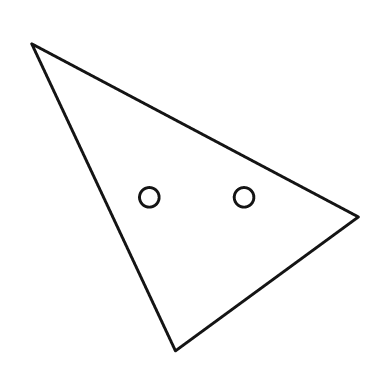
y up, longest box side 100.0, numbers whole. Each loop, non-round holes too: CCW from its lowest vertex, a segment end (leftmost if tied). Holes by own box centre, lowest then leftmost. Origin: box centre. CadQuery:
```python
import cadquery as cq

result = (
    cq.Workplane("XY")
    .moveTo(-6.0, -47.0)
    .lineTo(50.0, -6.0)
    .lineTo(-50.0, 47.0)
    .close()
    .moveTo(-14.0, 0.0)
    .circle(3.0)
    .moveTo(15.0, 0.0)
    .circle(3.0)
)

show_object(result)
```